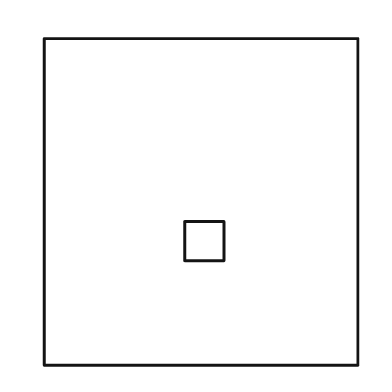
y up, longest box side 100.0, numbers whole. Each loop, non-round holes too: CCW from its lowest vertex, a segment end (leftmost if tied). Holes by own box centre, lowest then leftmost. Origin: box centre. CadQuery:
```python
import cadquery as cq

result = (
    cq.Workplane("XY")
    .moveTo(-48.0, -50.0)
    .lineTo(48.0, -50.0)
    .lineTo(48.0, 50.0)
    .lineTo(-48.0, 50.0)
    .close()
    .moveTo(-5.0, -18.0)
    .lineTo(7.0, -18.0)
    .lineTo(7.0, -6.0)
    .lineTo(-5.0, -6.0)
    .close()
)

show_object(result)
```